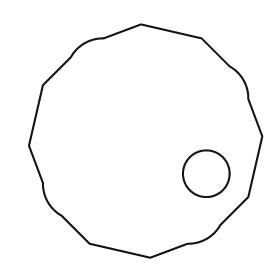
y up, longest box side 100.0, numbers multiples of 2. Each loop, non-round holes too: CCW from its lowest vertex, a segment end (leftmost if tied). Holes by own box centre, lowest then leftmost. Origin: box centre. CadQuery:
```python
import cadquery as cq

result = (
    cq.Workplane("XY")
    .moveTo(2.0, -50.0)
    .lineTo(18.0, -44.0)
    .threePointArc((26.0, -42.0), (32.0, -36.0))
    .lineTo(44.0, -24.0)
    .lineTo(50.0, 2.0)
    .lineTo(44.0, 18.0)
    .threePointArc((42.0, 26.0), (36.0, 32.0))
    .lineTo(24.0, 44.0)
    .lineTo(-2.0, 50.0)
    .lineTo(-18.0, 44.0)
    .threePointArc((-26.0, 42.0), (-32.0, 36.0))
    .lineTo(-44.0, 24.0)
    .lineTo(-50.0, -2.0)
    .lineTo(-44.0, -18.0)
    .threePointArc((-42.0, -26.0), (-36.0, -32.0))
    .lineTo(-24.0, -44.0)
    .close()
    .moveTo(26.0, -14.0)
    .circle(10.0)
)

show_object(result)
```